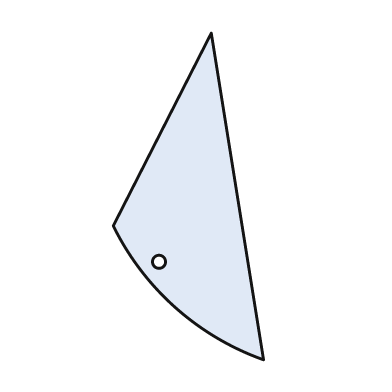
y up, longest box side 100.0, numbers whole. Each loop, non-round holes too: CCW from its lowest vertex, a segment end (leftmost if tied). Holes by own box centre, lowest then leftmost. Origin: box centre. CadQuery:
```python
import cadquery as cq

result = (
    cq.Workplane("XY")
    .moveTo(23.0, -50.0)
    .lineTo(7.0, 50.0)
    .lineTo(-23.0, -9.0)
    .threePointArc((-4.0, -34.0), (23.0, -50.0))
    .close()
    .moveTo(-9.0, -20.0)
    .circle(2.0)
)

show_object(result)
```